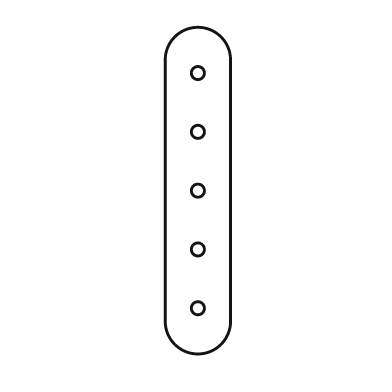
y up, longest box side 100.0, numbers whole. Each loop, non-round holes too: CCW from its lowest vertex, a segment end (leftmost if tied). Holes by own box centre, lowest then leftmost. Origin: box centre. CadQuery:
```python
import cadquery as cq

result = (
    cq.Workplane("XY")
    .moveTo(-10.0, -40.0)
    .threePointArc((0.0, -50.0), (10.0, -40.0))
    .lineTo(10.0, 40.0)
    .threePointArc((0.0, 50.0), (-10.0, 40.0))
    .close()
    .moveTo(0.0, -36.0)
    .circle(2.0)
    .moveTo(0.0, -18.0)
    .circle(2.0)
    .moveTo(0.0, 0.0)
    .circle(2.0)
    .moveTo(0.0, 18.0)
    .circle(2.0)
    .moveTo(0.0, 36.0)
    .circle(2.0)
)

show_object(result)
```